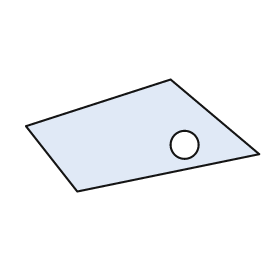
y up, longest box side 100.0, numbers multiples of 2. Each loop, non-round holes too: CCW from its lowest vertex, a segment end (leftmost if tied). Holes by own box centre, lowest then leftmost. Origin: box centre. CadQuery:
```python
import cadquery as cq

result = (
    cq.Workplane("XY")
    .moveTo(-28.0, -24.0)
    .lineTo(50.0, -8.0)
    .lineTo(12.0, 24.0)
    .lineTo(-50.0, 4.0)
    .close()
    .moveTo(18.0, -4.0)
    .circle(6.0)
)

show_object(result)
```